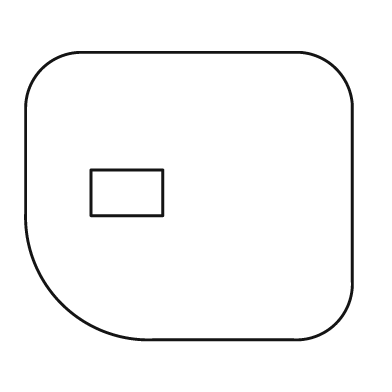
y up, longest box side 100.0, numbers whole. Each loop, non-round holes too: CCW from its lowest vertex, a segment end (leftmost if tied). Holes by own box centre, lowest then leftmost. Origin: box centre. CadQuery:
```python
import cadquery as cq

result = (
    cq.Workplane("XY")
    .moveTo(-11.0, -44.0)
    .lineTo(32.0, -44.0)
    .threePointArc((45.0, -39.0), (50.0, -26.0))
    .lineTo(50.0, 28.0)
    .threePointArc((45.0, 39.0), (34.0, 44.0))
    .lineTo(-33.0, 44.0)
    .threePointArc((-45.0, 39.0), (-50.0, 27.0))
    .lineTo(-50.0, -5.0)
    .threePointArc((-39.0, -33.0), (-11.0, -44.0))
    .close()
    .moveTo(-30.0, -6.0)
    .lineTo(-8.0, -6.0)
    .lineTo(-8.0, 8.0)
    .lineTo(-30.0, 8.0)
    .close()
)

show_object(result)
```